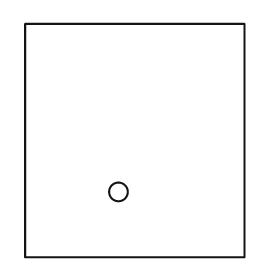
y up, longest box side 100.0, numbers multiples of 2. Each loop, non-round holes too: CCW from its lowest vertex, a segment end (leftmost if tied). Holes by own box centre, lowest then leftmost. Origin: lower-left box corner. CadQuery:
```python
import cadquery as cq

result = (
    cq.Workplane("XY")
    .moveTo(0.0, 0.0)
    .lineTo(94.0, 0.0)
    .lineTo(94.0, 100.0)
    .lineTo(0.0, 100.0)
    .close()
    .moveTo(40.0, 28.0)
    .circle(4.0)
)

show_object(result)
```